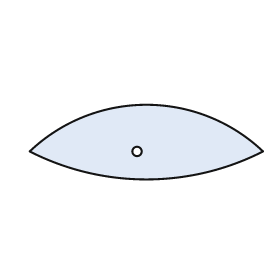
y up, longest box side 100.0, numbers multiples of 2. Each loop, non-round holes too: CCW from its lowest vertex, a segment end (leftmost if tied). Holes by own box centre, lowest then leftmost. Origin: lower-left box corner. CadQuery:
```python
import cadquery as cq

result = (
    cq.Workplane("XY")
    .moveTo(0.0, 12.0)
    .threePointArc((50.0, 0.0), (100.0, 12.0))
    .threePointArc((50.0, 32.0), (0.0, 12.0))
    .close()
    .moveTo(46.0, 12.0)
    .circle(2.0)
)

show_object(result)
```